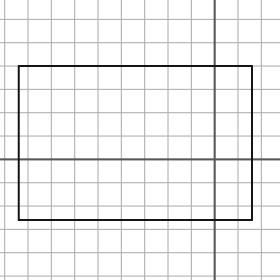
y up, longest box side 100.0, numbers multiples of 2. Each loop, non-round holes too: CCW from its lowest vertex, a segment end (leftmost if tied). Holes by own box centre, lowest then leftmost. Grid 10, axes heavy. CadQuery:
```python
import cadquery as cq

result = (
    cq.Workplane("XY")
    .moveTo(-84.0, -26.0)
    .lineTo(16.0, -26.0)
    .lineTo(16.0, 40.0)
    .lineTo(-84.0, 40.0)
    .close()
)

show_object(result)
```